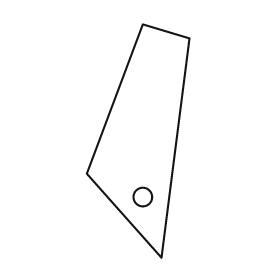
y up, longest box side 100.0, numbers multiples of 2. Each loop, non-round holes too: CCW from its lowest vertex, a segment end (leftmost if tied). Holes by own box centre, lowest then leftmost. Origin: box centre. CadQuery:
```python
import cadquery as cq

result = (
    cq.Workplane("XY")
    .moveTo(10.0, -50.0)
    .lineTo(22.0, 44.0)
    .lineTo(2.0, 50.0)
    .lineTo(-22.0, -14.0)
    .close()
    .moveTo(2.0, -24.0)
    .circle(4.0)
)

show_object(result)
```